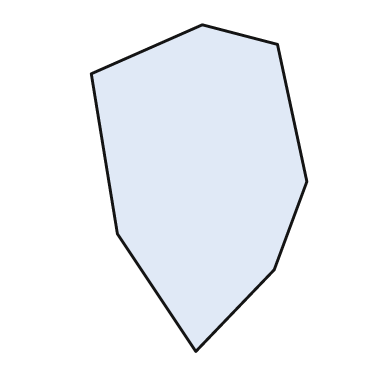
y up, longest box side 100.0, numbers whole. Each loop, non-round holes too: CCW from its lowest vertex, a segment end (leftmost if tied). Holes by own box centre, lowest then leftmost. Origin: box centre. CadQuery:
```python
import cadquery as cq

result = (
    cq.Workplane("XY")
    .moveTo(-1.0, -50.0)
    .lineTo(23.0, -25.0)
    .lineTo(33.0, 2.0)
    .lineTo(24.0, 44.0)
    .lineTo(1.0, 50.0)
    .lineTo(-33.0, 35.0)
    .lineTo(-25.0, -14.0)
    .close()
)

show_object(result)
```